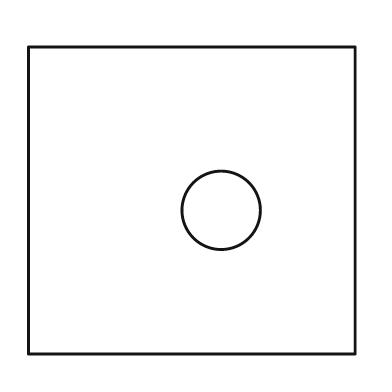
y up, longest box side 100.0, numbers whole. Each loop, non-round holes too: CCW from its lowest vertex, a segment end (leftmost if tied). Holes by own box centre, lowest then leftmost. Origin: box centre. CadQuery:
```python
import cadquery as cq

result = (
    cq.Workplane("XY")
    .moveTo(-50.0, -47.0)
    .lineTo(50.0, -47.0)
    .lineTo(50.0, 47.0)
    .lineTo(-50.0, 47.0)
    .close()
    .moveTo(9.0, -3.0)
    .circle(12.0)
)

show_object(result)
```